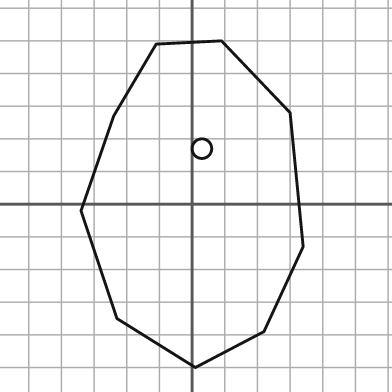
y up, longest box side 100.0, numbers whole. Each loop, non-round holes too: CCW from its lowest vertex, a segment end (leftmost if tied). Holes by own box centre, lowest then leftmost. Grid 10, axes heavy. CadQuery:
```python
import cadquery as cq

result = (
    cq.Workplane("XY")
    .moveTo(1.0, -50.0)
    .lineTo(22.0, -39.0)
    .lineTo(34.0, -13.0)
    .lineTo(30.0, 28.0)
    .lineTo(9.0, 50.0)
    .lineTo(-11.0, 49.0)
    .lineTo(-24.0, 27.0)
    .lineTo(-34.0, -2.0)
    .lineTo(-23.0, -35.0)
    .close()
    .moveTo(3.0, 17.0)
    .circle(3.0)
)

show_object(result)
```